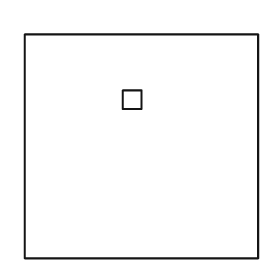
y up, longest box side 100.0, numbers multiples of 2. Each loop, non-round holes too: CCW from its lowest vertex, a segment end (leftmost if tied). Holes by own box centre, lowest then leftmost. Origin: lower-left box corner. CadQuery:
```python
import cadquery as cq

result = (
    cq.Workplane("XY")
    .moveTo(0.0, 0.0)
    .lineTo(100.0, 0.0)
    .lineTo(100.0, 96.0)
    .lineTo(0.0, 96.0)
    .close()
    .moveTo(42.0, 64.0)
    .lineTo(50.0, 64.0)
    .lineTo(50.0, 72.0)
    .lineTo(42.0, 72.0)
    .close()
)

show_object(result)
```